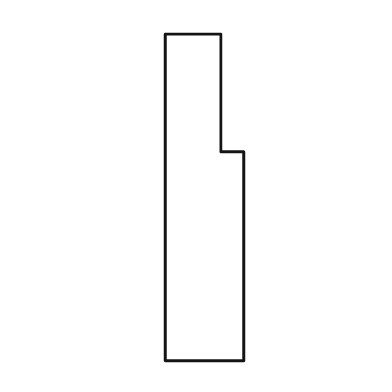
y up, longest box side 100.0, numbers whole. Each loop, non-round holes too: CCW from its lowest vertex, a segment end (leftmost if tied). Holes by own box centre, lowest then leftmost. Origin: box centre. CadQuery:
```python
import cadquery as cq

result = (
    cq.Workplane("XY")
    .moveTo(-12.0, -50.0)
    .lineTo(12.0, -50.0)
    .lineTo(12.0, 14.0)
    .lineTo(5.0, 14.0)
    .lineTo(5.0, 50.0)
    .lineTo(-12.0, 50.0)
    .close()
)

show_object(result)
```